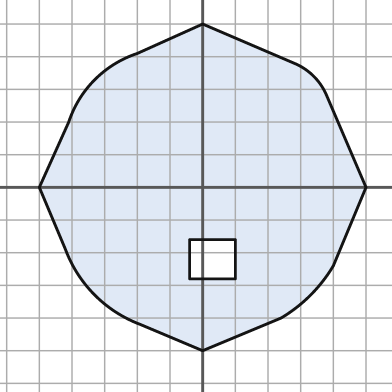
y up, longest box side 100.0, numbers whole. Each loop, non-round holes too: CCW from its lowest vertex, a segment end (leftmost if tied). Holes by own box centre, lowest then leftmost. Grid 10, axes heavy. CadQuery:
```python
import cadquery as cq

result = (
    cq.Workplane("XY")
    .moveTo(0.0, -50.0)
    .lineTo(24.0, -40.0)
    .threePointArc((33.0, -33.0), (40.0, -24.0))
    .lineTo(50.0, 0.0)
    .lineTo(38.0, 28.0)
    .threePointArc((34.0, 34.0), (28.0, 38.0))
    .lineTo(0.0, 50.0)
    .lineTo(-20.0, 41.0)
    .threePointArc((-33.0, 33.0), (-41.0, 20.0))
    .lineTo(-50.0, 0.0)
    .lineTo(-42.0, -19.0)
    .threePointArc((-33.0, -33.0), (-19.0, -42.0))
    .close()
    .moveTo(-4.0, -28.0)
    .lineTo(10.0, -28.0)
    .lineTo(10.0, -16.0)
    .lineTo(-4.0, -16.0)
    .close()
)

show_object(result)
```